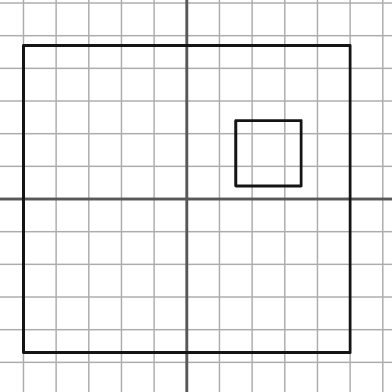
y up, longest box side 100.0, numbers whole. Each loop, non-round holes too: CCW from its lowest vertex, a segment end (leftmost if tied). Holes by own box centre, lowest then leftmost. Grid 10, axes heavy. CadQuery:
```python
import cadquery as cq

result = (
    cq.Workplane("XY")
    .moveTo(-50.0, -47.0)
    .lineTo(50.0, -47.0)
    .lineTo(50.0, 47.0)
    .lineTo(-50.0, 47.0)
    .close()
    .moveTo(15.0, 4.0)
    .lineTo(35.0, 4.0)
    .lineTo(35.0, 24.0)
    .lineTo(15.0, 24.0)
    .close()
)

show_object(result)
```